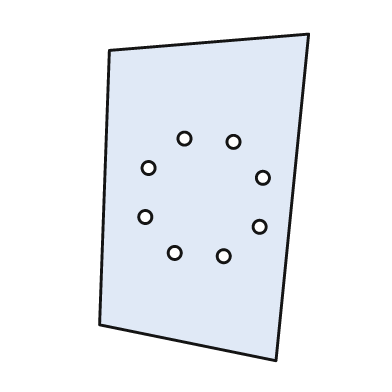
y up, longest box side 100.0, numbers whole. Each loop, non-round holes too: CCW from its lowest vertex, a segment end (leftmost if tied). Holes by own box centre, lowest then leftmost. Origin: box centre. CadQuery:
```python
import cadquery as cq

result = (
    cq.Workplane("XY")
    .moveTo(22.0, -50.0)
    .lineTo(32.0, 50.0)
    .lineTo(-29.0, 45.0)
    .lineTo(-32.0, -39.0)
    .close()
    .moveTo(6.0, -18.0)
    .circle(2.0)
    .moveTo(-9.0, -17.0)
    .circle(2.0)
    .moveTo(17.0, -9.0)
    .circle(2.0)
    .moveTo(-18.0, -6.0)
    .circle(2.0)
    .moveTo(18.0, 6.0)
    .circle(2.0)
    .moveTo(-17.0, 9.0)
    .circle(2.0)
    .moveTo(9.0, 17.0)
    .circle(2.0)
    .moveTo(-6.0, 18.0)
    .circle(2.0)
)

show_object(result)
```